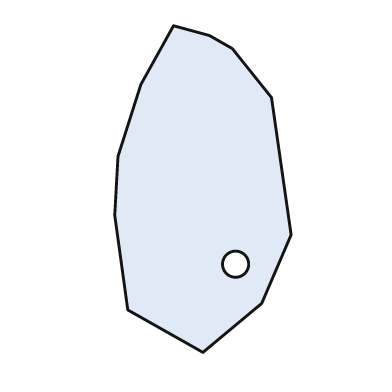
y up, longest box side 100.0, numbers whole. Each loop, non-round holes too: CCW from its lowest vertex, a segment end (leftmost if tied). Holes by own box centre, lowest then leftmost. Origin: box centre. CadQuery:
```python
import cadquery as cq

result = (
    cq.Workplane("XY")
    .moveTo(0.0, -50.0)
    .lineTo(18.0, -35.0)
    .lineTo(27.0, -14.0)
    .lineTo(21.0, 28.0)
    .lineTo(9.0, 43.0)
    .lineTo(2.0, 47.0)
    .lineTo(-9.0, 50.0)
    .lineTo(-19.0, 32.0)
    .lineTo(-26.0, 10.0)
    .lineTo(-27.0, -8.0)
    .lineTo(-23.0, -37.0)
    .close()
    .moveTo(10.0, -23.0)
    .circle(4.0)
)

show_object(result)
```